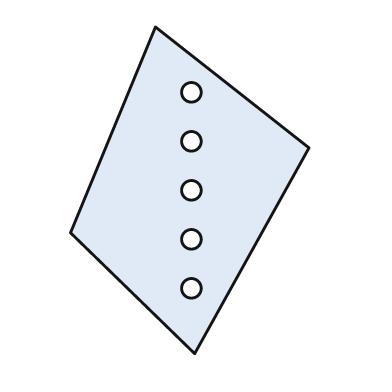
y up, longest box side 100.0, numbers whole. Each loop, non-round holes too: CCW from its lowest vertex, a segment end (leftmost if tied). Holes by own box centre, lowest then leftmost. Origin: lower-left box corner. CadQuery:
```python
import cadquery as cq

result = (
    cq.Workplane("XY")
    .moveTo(38.0, 0.0)
    .lineTo(73.0, 63.0)
    .lineTo(26.0, 100.0)
    .lineTo(0.0, 37.0)
    .close()
    .moveTo(37.0, 20.0)
    .circle(3.0)
    .moveTo(37.0, 35.0)
    .circle(3.0)
    .moveTo(37.0, 50.0)
    .circle(3.0)
    .moveTo(37.0, 65.0)
    .circle(3.0)
    .moveTo(37.0, 80.0)
    .circle(3.0)
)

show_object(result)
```